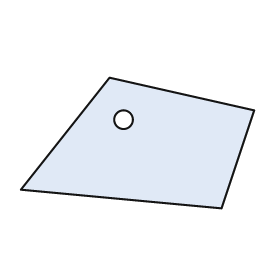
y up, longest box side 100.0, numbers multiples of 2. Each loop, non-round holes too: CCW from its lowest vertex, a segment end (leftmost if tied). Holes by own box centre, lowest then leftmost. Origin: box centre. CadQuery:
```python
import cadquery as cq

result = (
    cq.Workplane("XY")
    .moveTo(36.0, -28.0)
    .lineTo(50.0, 14.0)
    .lineTo(-12.0, 28.0)
    .lineTo(-50.0, -20.0)
    .close()
    .moveTo(-6.0, 10.0)
    .circle(4.0)
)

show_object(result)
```